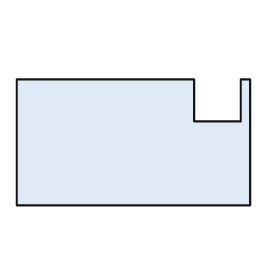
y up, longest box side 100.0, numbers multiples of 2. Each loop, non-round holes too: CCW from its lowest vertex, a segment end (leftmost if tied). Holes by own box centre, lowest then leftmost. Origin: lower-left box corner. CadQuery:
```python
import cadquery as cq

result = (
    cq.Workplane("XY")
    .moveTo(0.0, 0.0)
    .lineTo(100.0, 0.0)
    .lineTo(100.0, 54.0)
    .lineTo(96.0, 54.0)
    .lineTo(96.0, 36.0)
    .lineTo(76.0, 36.0)
    .lineTo(76.0, 54.0)
    .lineTo(0.0, 54.0)
    .close()
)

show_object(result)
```